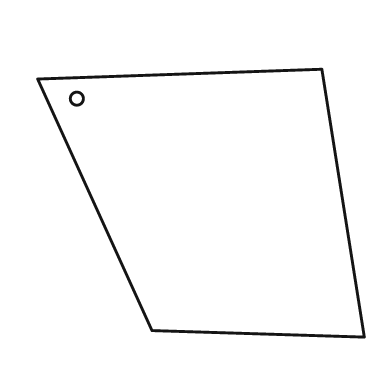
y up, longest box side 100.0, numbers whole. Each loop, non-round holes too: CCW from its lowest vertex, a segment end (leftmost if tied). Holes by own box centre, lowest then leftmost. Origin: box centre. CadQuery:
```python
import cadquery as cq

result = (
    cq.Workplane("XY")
    .moveTo(50.0, -41.0)
    .lineTo(37.0, 41.0)
    .lineTo(-50.0, 38.0)
    .lineTo(-15.0, -39.0)
    .close()
    .moveTo(-38.0, 32.0)
    .circle(2.0)
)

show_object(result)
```